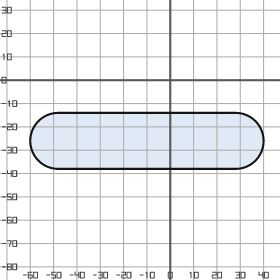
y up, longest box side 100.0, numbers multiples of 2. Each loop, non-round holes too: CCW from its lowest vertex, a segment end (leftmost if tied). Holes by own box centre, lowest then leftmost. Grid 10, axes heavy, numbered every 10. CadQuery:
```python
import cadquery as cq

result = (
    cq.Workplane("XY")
    .moveTo(-48.0, -38.0)
    .lineTo(28.0, -38.0)
    .threePointArc((40.0, -26.0), (28.0, -14.0))
    .lineTo(-48.0, -14.0)
    .threePointArc((-60.0, -26.0), (-48.0, -38.0))
    .close()
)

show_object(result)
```